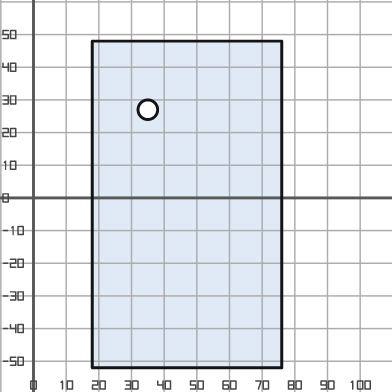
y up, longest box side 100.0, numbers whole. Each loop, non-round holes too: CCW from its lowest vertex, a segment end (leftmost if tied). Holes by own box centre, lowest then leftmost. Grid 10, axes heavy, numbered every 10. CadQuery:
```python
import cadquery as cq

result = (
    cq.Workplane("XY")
    .moveTo(18.0, -52.0)
    .lineTo(76.0, -52.0)
    .lineTo(76.0, 48.0)
    .lineTo(18.0, 48.0)
    .close()
    .moveTo(35.0, 27.0)
    .circle(3.0)
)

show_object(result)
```